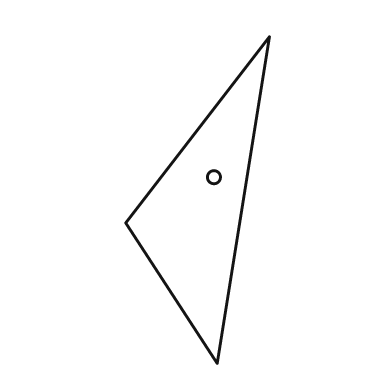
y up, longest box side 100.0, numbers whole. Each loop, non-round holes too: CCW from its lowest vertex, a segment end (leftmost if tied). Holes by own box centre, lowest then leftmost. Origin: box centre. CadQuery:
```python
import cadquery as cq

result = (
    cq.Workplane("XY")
    .moveTo(6.0, -50.0)
    .lineTo(22.0, 50.0)
    .lineTo(-22.0, -7.0)
    .close()
    .moveTo(5.0, 7.0)
    .circle(2.0)
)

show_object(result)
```